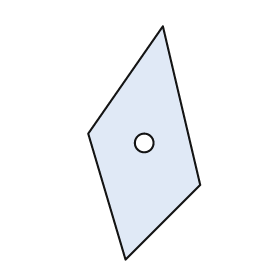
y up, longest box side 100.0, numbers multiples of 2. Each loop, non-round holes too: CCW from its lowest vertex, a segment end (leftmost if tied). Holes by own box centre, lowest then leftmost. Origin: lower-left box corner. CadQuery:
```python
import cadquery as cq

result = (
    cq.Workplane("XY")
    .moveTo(16.0, 0.0)
    .lineTo(48.0, 32.0)
    .lineTo(32.0, 100.0)
    .lineTo(0.0, 54.0)
    .close()
    .moveTo(24.0, 50.0)
    .circle(4.0)
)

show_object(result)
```